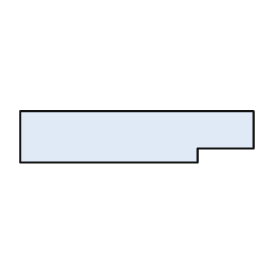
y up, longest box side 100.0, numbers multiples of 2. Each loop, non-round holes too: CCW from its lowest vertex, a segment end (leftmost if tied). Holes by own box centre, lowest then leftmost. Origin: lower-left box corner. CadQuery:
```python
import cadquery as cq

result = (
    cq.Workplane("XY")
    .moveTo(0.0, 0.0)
    .lineTo(76.0, 0.0)
    .lineTo(76.0, 6.0)
    .lineTo(100.0, 6.0)
    .lineTo(100.0, 22.0)
    .lineTo(0.0, 22.0)
    .close()
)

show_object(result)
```